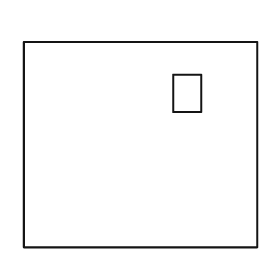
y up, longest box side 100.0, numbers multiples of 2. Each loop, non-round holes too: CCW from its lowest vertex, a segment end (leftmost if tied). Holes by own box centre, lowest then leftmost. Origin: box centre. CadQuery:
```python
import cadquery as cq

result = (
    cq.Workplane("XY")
    .moveTo(-50.0, -44.0)
    .lineTo(50.0, -44.0)
    .lineTo(50.0, 44.0)
    .lineTo(-50.0, 44.0)
    .close()
    .moveTo(14.0, 14.0)
    .lineTo(26.0, 14.0)
    .lineTo(26.0, 30.0)
    .lineTo(14.0, 30.0)
    .close()
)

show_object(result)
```